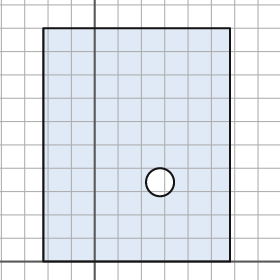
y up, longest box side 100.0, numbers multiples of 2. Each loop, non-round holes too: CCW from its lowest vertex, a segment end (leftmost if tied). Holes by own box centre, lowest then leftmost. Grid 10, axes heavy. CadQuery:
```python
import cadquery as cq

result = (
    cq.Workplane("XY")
    .moveTo(-22.0, 0.0)
    .lineTo(58.0, 0.0)
    .lineTo(58.0, 100.0)
    .lineTo(-22.0, 100.0)
    .close()
    .moveTo(28.0, 34.0)
    .circle(6.0)
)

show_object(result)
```